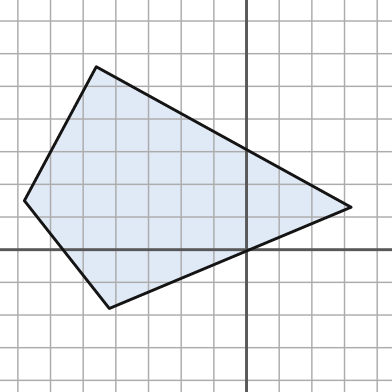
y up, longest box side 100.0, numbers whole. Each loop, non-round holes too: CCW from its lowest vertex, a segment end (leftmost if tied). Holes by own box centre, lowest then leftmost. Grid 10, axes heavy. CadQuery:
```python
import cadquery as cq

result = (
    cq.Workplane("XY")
    .moveTo(-42.0, -18.0)
    .lineTo(32.0, 13.0)
    .lineTo(-46.0, 56.0)
    .lineTo(-68.0, 15.0)
    .close()
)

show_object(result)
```